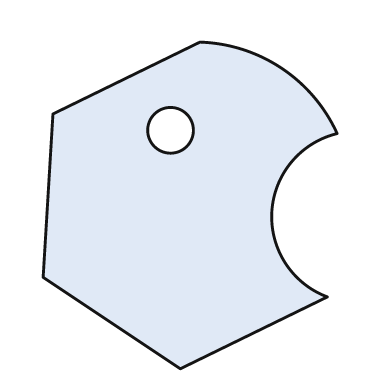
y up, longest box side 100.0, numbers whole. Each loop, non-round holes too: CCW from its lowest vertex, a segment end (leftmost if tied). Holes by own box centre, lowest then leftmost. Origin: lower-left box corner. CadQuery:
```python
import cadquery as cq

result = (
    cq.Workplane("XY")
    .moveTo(42.0, 0.0)
    .lineTo(87.0, 22.0)
    .threePointArc((70.0, 48.0), (90.0, 72.0))
    .threePointArc((73.0, 92.0), (48.0, 100.0))
    .lineTo(3.0, 78.0)
    .lineTo(0.0, 28.0)
    .close()
    .moveTo(39.0, 73.0)
    .circle(7.0)
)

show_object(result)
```